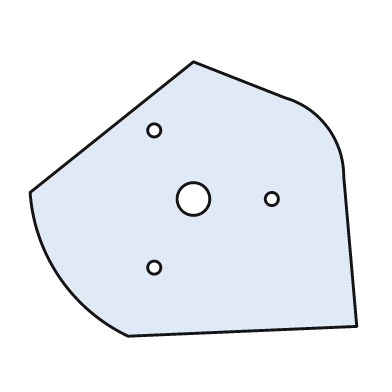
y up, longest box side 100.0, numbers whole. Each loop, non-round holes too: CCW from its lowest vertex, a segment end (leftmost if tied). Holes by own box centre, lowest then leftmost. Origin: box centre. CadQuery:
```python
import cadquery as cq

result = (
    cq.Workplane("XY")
    .moveTo(-20.0, -42.0)
    .lineTo(50.0, -39.0)
    .lineTo(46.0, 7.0)
    .threePointArc((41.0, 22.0), (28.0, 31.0))
    .lineTo(0.0, 42.0)
    .lineTo(-50.0, 2.0)
    .threePointArc((-41.0, -24.0), (-20.0, -42.0))
    .close()
    .moveTo(-12.0, -21.0)
    .circle(2.0)
    .moveTo(0.0, 0.0)
    .circle(5.0)
    .moveTo(24.0, 0.0)
    .circle(2.0)
    .moveTo(-12.0, 21.0)
    .circle(2.0)
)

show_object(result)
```